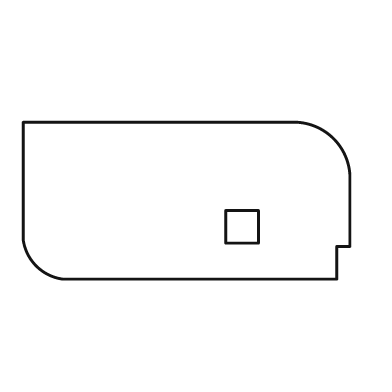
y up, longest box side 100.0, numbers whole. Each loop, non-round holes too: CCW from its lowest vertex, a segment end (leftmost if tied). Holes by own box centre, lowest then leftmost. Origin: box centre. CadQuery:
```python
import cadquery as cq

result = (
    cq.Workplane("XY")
    .moveTo(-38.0, -24.0)
    .lineTo(46.0, -24.0)
    .lineTo(46.0, -14.0)
    .lineTo(50.0, -14.0)
    .lineTo(50.0, 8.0)
    .threePointArc((45.0, 19.0), (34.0, 24.0))
    .lineTo(-50.0, 24.0)
    .lineTo(-50.0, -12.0)
    .threePointArc((-46.0, -20.0), (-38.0, -24.0))
    .close()
    .moveTo(12.0, -13.0)
    .lineTo(22.0, -13.0)
    .lineTo(22.0, -3.0)
    .lineTo(12.0, -3.0)
    .close()
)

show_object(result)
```